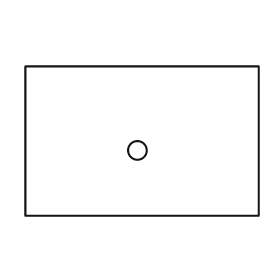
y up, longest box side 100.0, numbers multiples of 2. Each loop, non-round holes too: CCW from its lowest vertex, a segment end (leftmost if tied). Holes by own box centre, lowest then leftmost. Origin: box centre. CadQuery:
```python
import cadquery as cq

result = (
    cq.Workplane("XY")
    .moveTo(-50.0, -32.0)
    .lineTo(50.0, -32.0)
    .lineTo(50.0, 32.0)
    .lineTo(-50.0, 32.0)
    .close()
    .moveTo(-2.0, -4.0)
    .circle(4.0)
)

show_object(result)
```